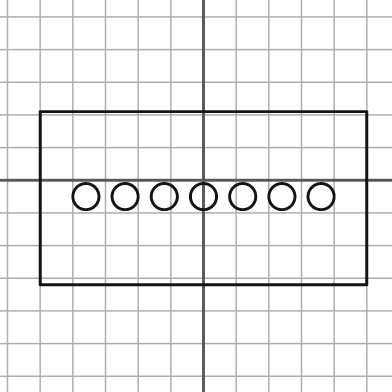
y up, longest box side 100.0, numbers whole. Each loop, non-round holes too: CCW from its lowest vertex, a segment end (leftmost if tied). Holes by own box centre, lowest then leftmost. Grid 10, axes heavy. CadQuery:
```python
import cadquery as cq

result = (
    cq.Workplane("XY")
    .moveTo(-50.0, -32.0)
    .lineTo(50.0, -32.0)
    .lineTo(50.0, 21.0)
    .lineTo(-50.0, 21.0)
    .close()
    .moveTo(-36.0, -5.0)
    .circle(4.0)
    .moveTo(-24.0, -5.0)
    .circle(4.0)
    .moveTo(-12.0, -5.0)
    .circle(4.0)
    .moveTo(0.0, -5.0)
    .circle(4.0)
    .moveTo(12.0, -5.0)
    .circle(4.0)
    .moveTo(24.0, -5.0)
    .circle(4.0)
    .moveTo(36.0, -5.0)
    .circle(4.0)
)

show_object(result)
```